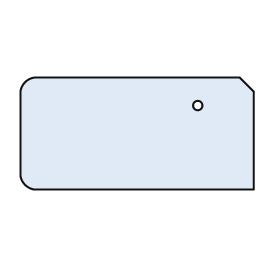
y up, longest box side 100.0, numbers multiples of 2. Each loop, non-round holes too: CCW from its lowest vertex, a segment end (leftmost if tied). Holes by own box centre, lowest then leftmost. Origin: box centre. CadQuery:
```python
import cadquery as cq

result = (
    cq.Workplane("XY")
    .moveTo(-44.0, -24.0)
    .lineTo(50.0, -24.0)
    .lineTo(50.0, 18.0)
    .lineTo(44.0, 24.0)
    .lineTo(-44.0, 24.0)
    .threePointArc((-48.0, 22.0), (-50.0, 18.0))
    .lineTo(-50.0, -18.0)
    .threePointArc((-48.0, -22.0), (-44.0, -24.0))
    .close()
    .moveTo(26.0, 12.0)
    .circle(2.0)
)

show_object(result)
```